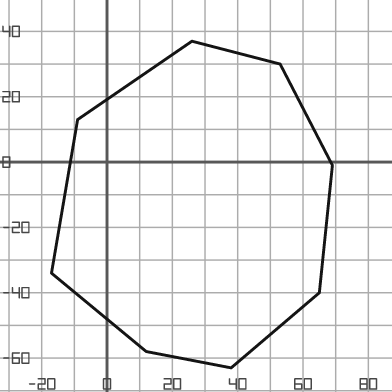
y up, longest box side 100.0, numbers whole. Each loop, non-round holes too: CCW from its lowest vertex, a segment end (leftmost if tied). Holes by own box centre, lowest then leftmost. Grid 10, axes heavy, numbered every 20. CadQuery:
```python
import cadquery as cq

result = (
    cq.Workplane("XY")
    .moveTo(38.0, -63.0)
    .lineTo(65.0, -40.0)
    .lineTo(69.0, -1.0)
    .lineTo(53.0, 30.0)
    .lineTo(26.0, 37.0)
    .lineTo(-9.0, 13.0)
    .lineTo(-17.0, -34.0)
    .lineTo(12.0, -58.0)
    .close()
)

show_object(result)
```